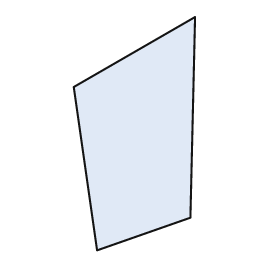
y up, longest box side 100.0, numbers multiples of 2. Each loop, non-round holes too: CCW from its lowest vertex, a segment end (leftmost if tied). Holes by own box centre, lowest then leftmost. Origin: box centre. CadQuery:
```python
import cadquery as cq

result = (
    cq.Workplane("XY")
    .moveTo(-16.0, -50.0)
    .lineTo(24.0, -36.0)
    .lineTo(26.0, 50.0)
    .lineTo(-26.0, 20.0)
    .close()
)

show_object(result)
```